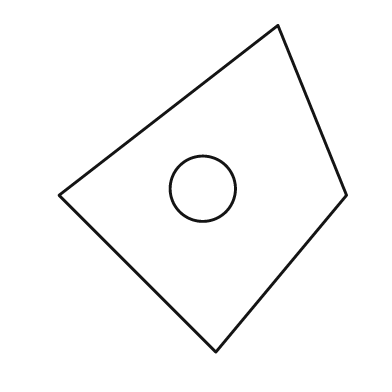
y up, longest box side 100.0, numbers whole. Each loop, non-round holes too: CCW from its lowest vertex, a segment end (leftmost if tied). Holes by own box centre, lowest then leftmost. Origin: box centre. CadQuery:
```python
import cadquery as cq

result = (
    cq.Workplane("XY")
    .moveTo(4.0, -50.0)
    .lineTo(44.0, -2.0)
    .lineTo(23.0, 50.0)
    .lineTo(-44.0, -2.0)
    .close()
    .moveTo(0.0, 0.0)
    .circle(10.0)
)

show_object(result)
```